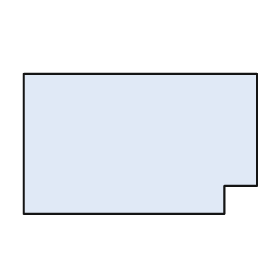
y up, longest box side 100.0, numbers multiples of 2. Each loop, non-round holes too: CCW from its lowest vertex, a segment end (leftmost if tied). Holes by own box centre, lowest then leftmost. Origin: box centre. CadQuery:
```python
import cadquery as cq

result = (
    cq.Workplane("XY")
    .moveTo(-50.0, -30.0)
    .lineTo(36.0, -30.0)
    .lineTo(36.0, -18.0)
    .lineTo(50.0, -18.0)
    .lineTo(50.0, 30.0)
    .lineTo(-50.0, 30.0)
    .close()
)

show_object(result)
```